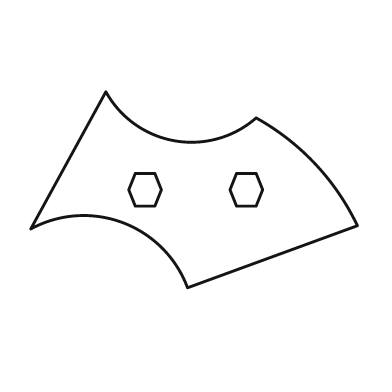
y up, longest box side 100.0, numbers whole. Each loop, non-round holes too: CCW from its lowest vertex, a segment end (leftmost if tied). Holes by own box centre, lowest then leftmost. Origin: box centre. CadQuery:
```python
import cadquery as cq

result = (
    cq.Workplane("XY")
    .moveTo(-2.0, -30.0)
    .lineTo(50.0, -11.0)
    .threePointArc((37.0, 8.0), (19.0, 22.0))
    .threePointArc((-6.0, 15.0), (-27.0, 30.0))
    .lineTo(-50.0, -12.0)
    .threePointArc((-22.0, -10.0), (-2.0, -30.0))
    .close()
    .moveTo(-18.0, -5.0)
    .lineTo(-12.0, -5.0)
    .lineTo(-10.0, 0.0)
    .lineTo(-12.0, 5.0)
    .lineTo(-18.0, 5.0)
    .lineTo(-20.0, 0.0)
    .close()
    .moveTo(13.0, -5.0)
    .lineTo(19.0, -5.0)
    .lineTo(21.0, 0.0)
    .lineTo(19.0, 5.0)
    .lineTo(13.0, 5.0)
    .lineTo(11.0, 0.0)
    .close()
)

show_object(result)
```